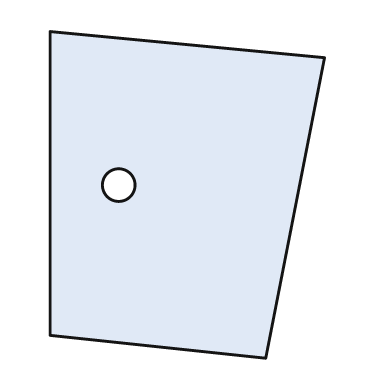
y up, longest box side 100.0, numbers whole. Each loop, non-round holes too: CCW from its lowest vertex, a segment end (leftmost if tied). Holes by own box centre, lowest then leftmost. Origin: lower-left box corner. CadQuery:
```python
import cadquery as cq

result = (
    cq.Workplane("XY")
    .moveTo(66.0, 0.0)
    .lineTo(84.0, 92.0)
    .lineTo(0.0, 100.0)
    .lineTo(0.0, 7.0)
    .close()
    .moveTo(21.0, 53.0)
    .circle(5.0)
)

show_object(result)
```